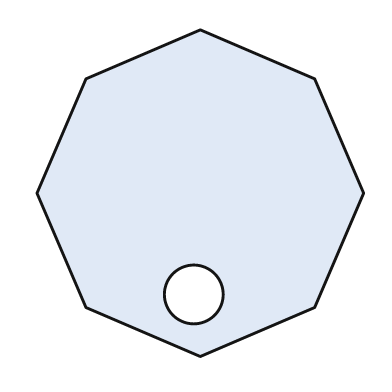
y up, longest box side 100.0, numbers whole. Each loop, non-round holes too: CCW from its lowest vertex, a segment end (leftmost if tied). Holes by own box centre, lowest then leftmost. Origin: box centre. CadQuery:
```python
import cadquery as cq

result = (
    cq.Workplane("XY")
    .moveTo(0.0, -50.0)
    .lineTo(35.0, -35.0)
    .lineTo(50.0, 0.0)
    .lineTo(35.0, 35.0)
    .lineTo(0.0, 50.0)
    .lineTo(-35.0, 35.0)
    .lineTo(-50.0, 0.0)
    .lineTo(-35.0, -35.0)
    .close()
    .moveTo(-2.0, -31.0)
    .circle(9.0)
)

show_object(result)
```